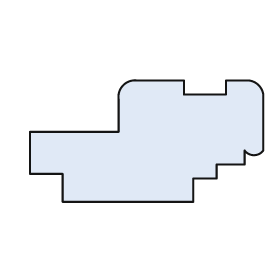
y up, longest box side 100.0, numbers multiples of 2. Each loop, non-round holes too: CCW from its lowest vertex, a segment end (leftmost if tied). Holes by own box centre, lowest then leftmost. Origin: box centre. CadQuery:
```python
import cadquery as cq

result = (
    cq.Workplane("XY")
    .moveTo(-36.0, -26.0)
    .lineTo(20.0, -26.0)
    .lineTo(20.0, -16.0)
    .lineTo(30.0, -16.0)
    .lineTo(30.0, -10.0)
    .lineTo(42.0, -10.0)
    .lineTo(42.0, -4.0)
    .threePointArc((46.0, -6.0), (50.0, -4.0))
    .lineTo(50.0, 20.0)
    .threePointArc((48.0, 24.0), (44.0, 26.0))
    .lineTo(34.0, 26.0)
    .lineTo(34.0, 20.0)
    .lineTo(16.0, 20.0)
    .lineTo(16.0, 26.0)
    .lineTo(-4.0, 26.0)
    .threePointArc((-10.0, 24.0), (-12.0, 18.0))
    .lineTo(-12.0, 4.0)
    .lineTo(-50.0, 4.0)
    .lineTo(-50.0, -14.0)
    .lineTo(-36.0, -14.0)
    .close()
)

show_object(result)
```